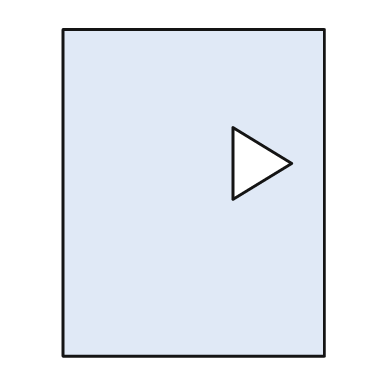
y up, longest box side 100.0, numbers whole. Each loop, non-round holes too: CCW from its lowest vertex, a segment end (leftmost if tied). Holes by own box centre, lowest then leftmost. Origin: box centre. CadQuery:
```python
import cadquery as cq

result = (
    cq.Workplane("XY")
    .moveTo(-40.0, -50.0)
    .lineTo(40.0, -50.0)
    .lineTo(40.0, 50.0)
    .lineTo(-40.0, 50.0)
    .close()
    .moveTo(12.0, -2.0)
    .lineTo(30.0, 9.0)
    .lineTo(12.0, 20.0)
    .close()
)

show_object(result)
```